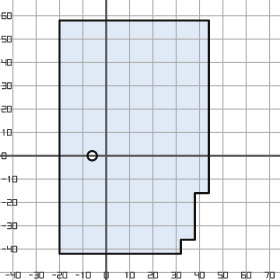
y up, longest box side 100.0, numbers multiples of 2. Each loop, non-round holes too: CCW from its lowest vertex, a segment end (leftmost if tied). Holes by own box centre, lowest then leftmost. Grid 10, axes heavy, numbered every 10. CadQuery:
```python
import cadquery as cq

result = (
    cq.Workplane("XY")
    .moveTo(-20.0, -42.0)
    .lineTo(32.0, -42.0)
    .lineTo(32.0, -36.0)
    .lineTo(38.0, -36.0)
    .lineTo(38.0, -16.0)
    .lineTo(44.0, -16.0)
    .lineTo(44.0, 58.0)
    .lineTo(-20.0, 58.0)
    .close()
    .moveTo(-6.0, 0.0)
    .circle(2.0)
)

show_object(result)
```